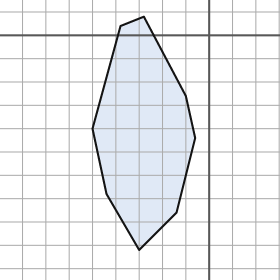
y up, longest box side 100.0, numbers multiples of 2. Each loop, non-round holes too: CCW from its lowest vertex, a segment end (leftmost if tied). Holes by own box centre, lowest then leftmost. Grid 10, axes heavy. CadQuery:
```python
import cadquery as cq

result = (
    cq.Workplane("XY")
    .moveTo(-30.0, -92.0)
    .lineTo(-14.0, -76.0)
    .lineTo(-6.0, -44.0)
    .lineTo(-10.0, -26.0)
    .lineTo(-28.0, 8.0)
    .lineTo(-38.0, 4.0)
    .lineTo(-50.0, -40.0)
    .lineTo(-44.0, -68.0)
    .close()
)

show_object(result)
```